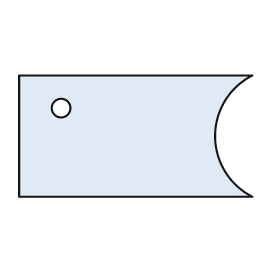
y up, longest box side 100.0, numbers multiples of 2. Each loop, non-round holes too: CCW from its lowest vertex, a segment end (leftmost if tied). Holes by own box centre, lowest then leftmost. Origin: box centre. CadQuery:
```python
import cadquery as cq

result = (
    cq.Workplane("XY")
    .moveTo(-50.0, -26.0)
    .lineTo(50.0, -26.0)
    .threePointArc((34.0, 0.0), (50.0, 26.0))
    .lineTo(-50.0, 26.0)
    .close()
    .moveTo(-32.0, 12.0)
    .circle(4.0)
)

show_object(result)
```